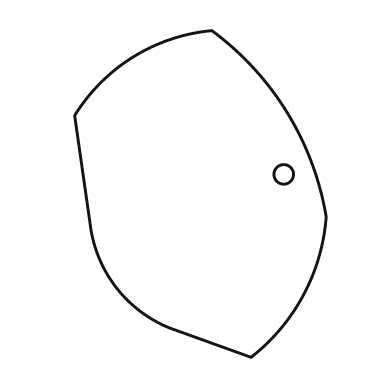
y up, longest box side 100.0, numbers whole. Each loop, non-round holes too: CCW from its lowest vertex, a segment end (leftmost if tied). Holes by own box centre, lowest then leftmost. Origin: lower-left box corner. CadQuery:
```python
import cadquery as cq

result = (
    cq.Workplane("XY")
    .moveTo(54.0, 0.0)
    .threePointArc((70.0, 19.0), (77.0, 43.0))
    .threePointArc((65.0, 75.0), (42.0, 100.0))
    .threePointArc((18.0, 92.0), (0.0, 74.0))
    .lineTo(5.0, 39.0)
    .threePointArc((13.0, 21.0), (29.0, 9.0))
    .close()
    .moveTo(64.0, 56.0)
    .circle(3.0)
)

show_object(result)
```